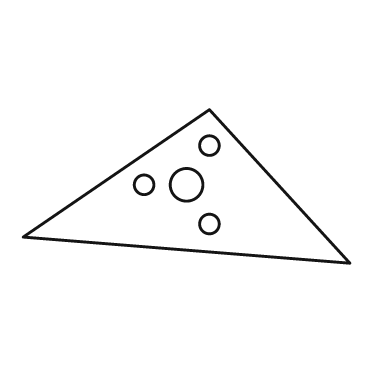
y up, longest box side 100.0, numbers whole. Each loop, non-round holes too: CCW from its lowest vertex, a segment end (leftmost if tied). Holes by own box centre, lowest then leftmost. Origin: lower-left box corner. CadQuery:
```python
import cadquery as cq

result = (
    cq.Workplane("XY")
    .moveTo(100.0, 0.0)
    .lineTo(57.0, 47.0)
    .lineTo(0.0, 8.0)
    .close()
    .moveTo(57.0, 12.0)
    .circle(3.0)
    .moveTo(37.0, 24.0)
    .circle(3.0)
    .moveTo(50.0, 24.0)
    .circle(5.0)
    .moveTo(57.0, 36.0)
    .circle(3.0)
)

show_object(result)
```